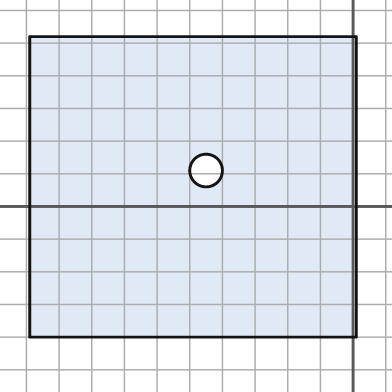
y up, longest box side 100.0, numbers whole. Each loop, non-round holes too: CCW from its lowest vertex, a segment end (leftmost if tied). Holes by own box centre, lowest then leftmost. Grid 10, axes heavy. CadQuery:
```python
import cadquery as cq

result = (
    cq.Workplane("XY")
    .moveTo(-99.0, -40.0)
    .lineTo(1.0, -40.0)
    .lineTo(1.0, 52.0)
    .lineTo(-99.0, 52.0)
    .close()
    .moveTo(-45.0, 11.0)
    .circle(5.0)
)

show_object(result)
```